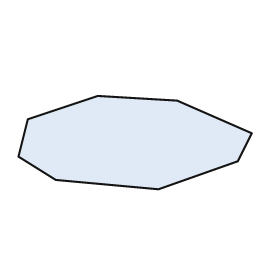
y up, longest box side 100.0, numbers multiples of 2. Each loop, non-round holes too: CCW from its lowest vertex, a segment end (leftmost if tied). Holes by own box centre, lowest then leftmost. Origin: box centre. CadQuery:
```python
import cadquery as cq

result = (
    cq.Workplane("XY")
    .moveTo(10.0, -20.0)
    .lineTo(44.0, -8.0)
    .lineTo(50.0, 4.0)
    .lineTo(18.0, 18.0)
    .lineTo(-16.0, 20.0)
    .lineTo(-46.0, 10.0)
    .lineTo(-50.0, -6.0)
    .lineTo(-34.0, -16.0)
    .close()
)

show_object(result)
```